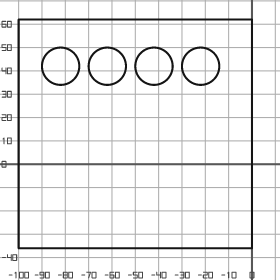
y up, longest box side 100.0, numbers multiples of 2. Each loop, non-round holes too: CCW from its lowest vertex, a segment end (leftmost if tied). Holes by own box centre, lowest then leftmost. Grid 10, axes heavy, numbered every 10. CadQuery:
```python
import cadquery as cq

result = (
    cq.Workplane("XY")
    .moveTo(-100.0, -36.0)
    .lineTo(0.0, -36.0)
    .lineTo(0.0, 62.0)
    .lineTo(-100.0, 62.0)
    .close()
    .moveTo(-82.0, 42.0)
    .circle(8.0)
    .moveTo(-62.0, 42.0)
    .circle(8.0)
    .moveTo(-42.0, 42.0)
    .circle(8.0)
    .moveTo(-22.0, 42.0)
    .circle(8.0)
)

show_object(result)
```